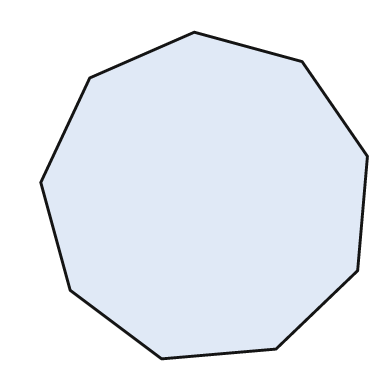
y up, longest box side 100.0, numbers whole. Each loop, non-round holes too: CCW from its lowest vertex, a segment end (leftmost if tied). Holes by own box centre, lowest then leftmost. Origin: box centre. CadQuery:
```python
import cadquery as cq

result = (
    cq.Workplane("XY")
    .moveTo(-13.0, -50.0)
    .lineTo(22.0, -47.0)
    .lineTo(47.0, -23.0)
    .lineTo(50.0, 12.0)
    .lineTo(30.0, 41.0)
    .lineTo(-3.0, 50.0)
    .lineTo(-35.0, 36.0)
    .lineTo(-50.0, 4.0)
    .lineTo(-41.0, -29.0)
    .close()
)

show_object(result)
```